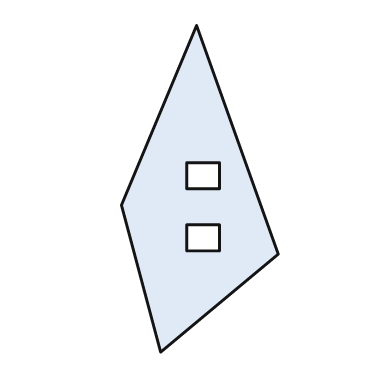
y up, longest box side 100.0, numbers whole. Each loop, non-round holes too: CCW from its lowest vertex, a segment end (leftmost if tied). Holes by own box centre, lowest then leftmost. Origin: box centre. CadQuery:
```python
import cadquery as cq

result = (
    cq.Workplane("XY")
    .moveTo(-12.0, -50.0)
    .lineTo(24.0, -20.0)
    .lineTo(-1.0, 50.0)
    .lineTo(-24.0, -5.0)
    .close()
    .moveTo(-4.0, -19.0)
    .lineTo(6.0, -19.0)
    .lineTo(6.0, -11.0)
    .lineTo(-4.0, -11.0)
    .close()
    .moveTo(-4.0, 0.0)
    .lineTo(6.0, 0.0)
    .lineTo(6.0, 8.0)
    .lineTo(-4.0, 8.0)
    .close()
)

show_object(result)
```